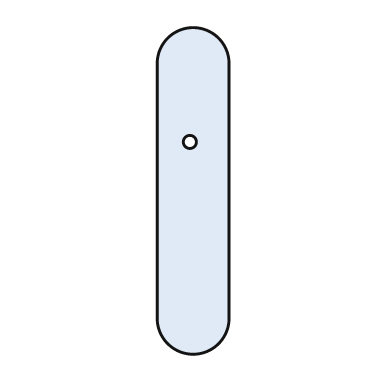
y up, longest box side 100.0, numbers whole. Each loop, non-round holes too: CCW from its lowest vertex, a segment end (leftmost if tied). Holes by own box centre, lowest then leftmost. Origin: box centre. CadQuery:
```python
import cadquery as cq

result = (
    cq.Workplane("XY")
    .moveTo(-11.0, -39.0)
    .threePointArc((0.0, -50.0), (11.0, -39.0))
    .lineTo(11.0, 39.0)
    .threePointArc((0.0, 50.0), (-11.0, 39.0))
    .close()
    .moveTo(-1.0, 15.0)
    .circle(2.0)
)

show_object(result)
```